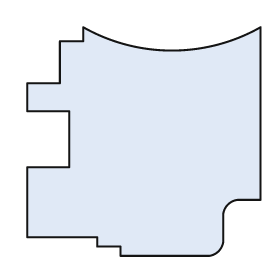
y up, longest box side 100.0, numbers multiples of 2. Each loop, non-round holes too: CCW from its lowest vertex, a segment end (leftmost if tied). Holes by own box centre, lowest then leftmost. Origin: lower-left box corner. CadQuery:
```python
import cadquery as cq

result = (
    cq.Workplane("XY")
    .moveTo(40.0, 0.0)
    .lineTo(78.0, 0.0)
    .threePointArc((82.0, 2.0), (84.0, 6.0))
    .lineTo(84.0, 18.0)
    .threePointArc((86.0, 22.0), (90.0, 24.0))
    .lineTo(100.0, 24.0)
    .lineTo(100.0, 98.0)
    .threePointArc((62.0, 88.0), (24.0, 98.0))
    .lineTo(24.0, 92.0)
    .lineTo(14.0, 92.0)
    .lineTo(14.0, 74.0)
    .lineTo(0.0, 74.0)
    .lineTo(0.0, 62.0)
    .lineTo(18.0, 62.0)
    .lineTo(18.0, 38.0)
    .lineTo(0.0, 38.0)
    .lineTo(0.0, 8.0)
    .lineTo(30.0, 8.0)
    .lineTo(30.0, 4.0)
    .lineTo(40.0, 4.0)
    .close()
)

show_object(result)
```